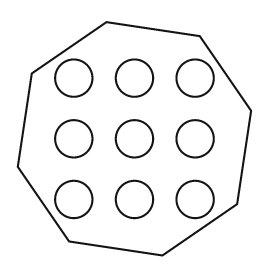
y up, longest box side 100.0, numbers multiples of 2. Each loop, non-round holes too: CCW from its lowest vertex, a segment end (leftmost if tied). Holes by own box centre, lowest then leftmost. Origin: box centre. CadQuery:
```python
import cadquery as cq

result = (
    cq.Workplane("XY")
    .moveTo(12.0, -50.0)
    .lineTo(44.0, -28.0)
    .lineTo(50.0, 12.0)
    .lineTo(28.0, 44.0)
    .lineTo(-12.0, 50.0)
    .lineTo(-44.0, 28.0)
    .lineTo(-50.0, -12.0)
    .lineTo(-28.0, -44.0)
    .close()
    .moveTo(-26.0, -26.0)
    .circle(8.0)
    .moveTo(0.0, -26.0)
    .circle(8.0)
    .moveTo(26.0, -26.0)
    .circle(8.0)
    .moveTo(-26.0, 0.0)
    .circle(8.0)
    .moveTo(0.0, 0.0)
    .circle(8.0)
    .moveTo(26.0, 0.0)
    .circle(8.0)
    .moveTo(-26.0, 26.0)
    .circle(8.0)
    .moveTo(0.0, 26.0)
    .circle(8.0)
    .moveTo(26.0, 26.0)
    .circle(8.0)
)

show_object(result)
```